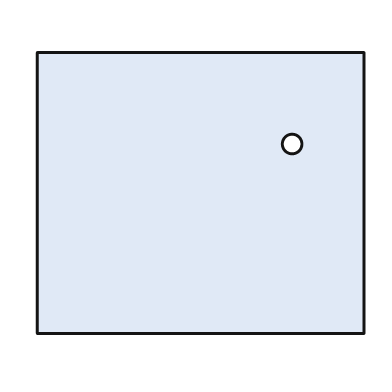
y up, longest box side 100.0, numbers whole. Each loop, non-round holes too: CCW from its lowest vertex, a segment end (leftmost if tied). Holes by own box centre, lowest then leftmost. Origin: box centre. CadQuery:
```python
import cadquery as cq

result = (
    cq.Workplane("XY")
    .moveTo(-50.0, -43.0)
    .lineTo(50.0, -43.0)
    .lineTo(50.0, 43.0)
    .lineTo(-50.0, 43.0)
    .close()
    .moveTo(28.0, 15.0)
    .circle(3.0)
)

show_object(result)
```